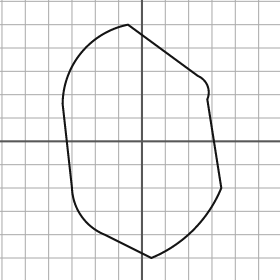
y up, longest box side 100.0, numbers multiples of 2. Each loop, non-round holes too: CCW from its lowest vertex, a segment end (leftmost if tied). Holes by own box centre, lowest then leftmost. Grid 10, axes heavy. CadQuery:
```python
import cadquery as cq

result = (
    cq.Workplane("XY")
    .moveTo(4.0, -50.0)
    .threePointArc((22.0, -38.0), (34.0, -20.0))
    .lineTo(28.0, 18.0)
    .threePointArc((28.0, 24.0), (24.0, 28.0))
    .lineTo(-6.0, 50.0)
    .threePointArc((-26.0, 38.0), (-34.0, 16.0))
    .lineTo(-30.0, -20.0)
    .threePointArc((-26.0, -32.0), (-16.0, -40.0))
    .close()
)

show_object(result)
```